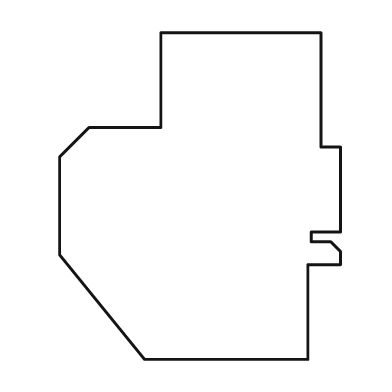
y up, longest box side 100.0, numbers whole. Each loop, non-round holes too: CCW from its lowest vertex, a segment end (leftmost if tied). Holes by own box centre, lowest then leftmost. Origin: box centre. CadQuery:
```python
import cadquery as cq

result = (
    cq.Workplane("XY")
    .moveTo(-17.0, -50.0)
    .lineTo(33.0, -50.0)
    .lineTo(33.0, -21.0)
    .lineTo(43.0, -21.0)
    .lineTo(43.0, -17.0)
    .lineTo(40.0, -14.0)
    .lineTo(34.0, -14.0)
    .lineTo(34.0, -11.0)
    .lineTo(43.0, -11.0)
    .lineTo(43.0, 15.0)
    .lineTo(37.0, 15.0)
    .lineTo(37.0, 50.0)
    .lineTo(-12.0, 50.0)
    .lineTo(-12.0, 21.0)
    .lineTo(-34.0, 21.0)
    .lineTo(-43.0, 12.0)
    .lineTo(-43.0, -18.0)
    .close()
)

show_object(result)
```